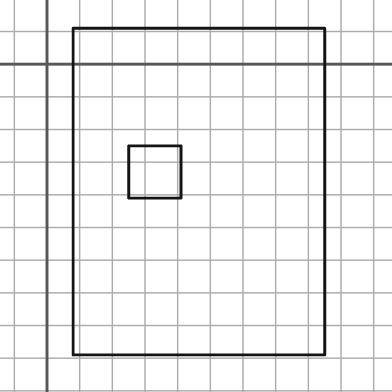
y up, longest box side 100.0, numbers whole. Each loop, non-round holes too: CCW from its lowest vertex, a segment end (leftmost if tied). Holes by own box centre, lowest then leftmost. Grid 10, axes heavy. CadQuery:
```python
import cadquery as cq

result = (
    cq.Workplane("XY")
    .moveTo(8.0, -89.0)
    .lineTo(85.0, -89.0)
    .lineTo(85.0, 11.0)
    .lineTo(8.0, 11.0)
    .close()
    .moveTo(25.0, -41.0)
    .lineTo(41.0, -41.0)
    .lineTo(41.0, -25.0)
    .lineTo(25.0, -25.0)
    .close()
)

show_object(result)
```